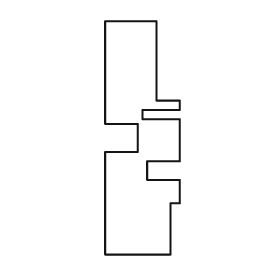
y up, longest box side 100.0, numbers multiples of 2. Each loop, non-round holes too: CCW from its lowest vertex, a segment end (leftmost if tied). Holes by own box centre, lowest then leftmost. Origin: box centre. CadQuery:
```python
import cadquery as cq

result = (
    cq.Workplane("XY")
    .moveTo(-16.0, -50.0)
    .lineTo(12.0, -50.0)
    .lineTo(12.0, -28.0)
    .lineTo(16.0, -28.0)
    .lineTo(16.0, -18.0)
    .lineTo(2.0, -18.0)
    .lineTo(2.0, -10.0)
    .lineTo(16.0, -10.0)
    .lineTo(16.0, 8.0)
    .lineTo(0.0, 8.0)
    .lineTo(0.0, 12.0)
    .lineTo(16.0, 12.0)
    .lineTo(16.0, 16.0)
    .lineTo(6.0, 16.0)
    .lineTo(6.0, 50.0)
    .lineTo(-16.0, 50.0)
    .lineTo(-16.0, 6.0)
    .lineTo(-2.0, 6.0)
    .lineTo(-2.0, -6.0)
    .lineTo(-16.0, -6.0)
    .close()
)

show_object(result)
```